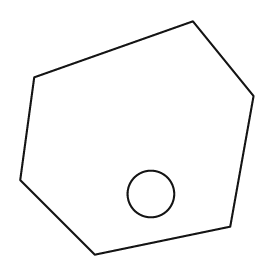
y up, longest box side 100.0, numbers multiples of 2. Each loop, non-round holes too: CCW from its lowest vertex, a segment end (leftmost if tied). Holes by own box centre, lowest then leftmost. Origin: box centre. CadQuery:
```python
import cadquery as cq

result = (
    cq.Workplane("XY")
    .moveTo(-18.0, -50.0)
    .lineTo(40.0, -38.0)
    .lineTo(50.0, 18.0)
    .lineTo(24.0, 50.0)
    .lineTo(-44.0, 26.0)
    .lineTo(-50.0, -18.0)
    .close()
    .moveTo(6.0, -24.0)
    .circle(10.0)
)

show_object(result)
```